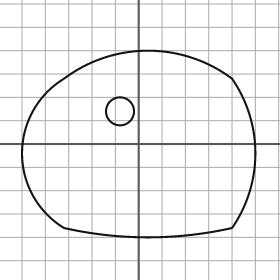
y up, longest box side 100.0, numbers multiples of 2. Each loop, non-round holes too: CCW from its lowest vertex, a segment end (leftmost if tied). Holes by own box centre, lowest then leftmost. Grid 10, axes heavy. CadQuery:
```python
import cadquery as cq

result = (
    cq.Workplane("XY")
    .moveTo(-32.0, -36.0)
    .threePointArc((4.0, -40.0), (40.0, -36.0))
    .threePointArc((50.0, -4.0), (40.0, 28.0))
    .threePointArc((4.0, 40.0), (-32.0, 28.0))
    .threePointArc((-50.0, -4.0), (-32.0, -36.0))
    .close()
    .moveTo(-8.0, 14.0)
    .circle(6.0)
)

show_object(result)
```